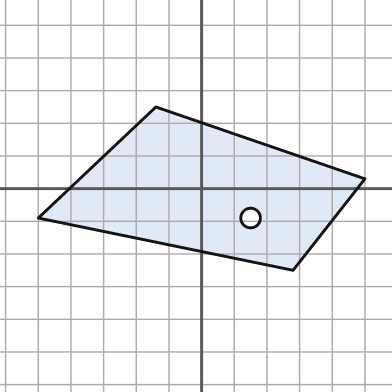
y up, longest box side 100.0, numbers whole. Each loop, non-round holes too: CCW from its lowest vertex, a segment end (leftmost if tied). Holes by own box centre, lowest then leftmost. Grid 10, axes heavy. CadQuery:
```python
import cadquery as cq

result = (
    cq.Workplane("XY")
    .moveTo(28.0, -25.0)
    .lineTo(50.0, 3.0)
    .lineTo(-14.0, 25.0)
    .lineTo(-50.0, -9.0)
    .close()
    .moveTo(15.0, -9.0)
    .circle(3.0)
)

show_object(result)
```